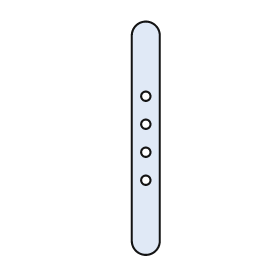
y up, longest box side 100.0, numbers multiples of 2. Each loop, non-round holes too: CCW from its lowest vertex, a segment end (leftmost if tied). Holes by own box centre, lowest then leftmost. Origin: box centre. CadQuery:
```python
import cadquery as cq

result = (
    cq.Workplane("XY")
    .moveTo(-6.0, -44.0)
    .threePointArc((0.0, -50.0), (6.0, -44.0))
    .lineTo(6.0, 44.0)
    .threePointArc((0.0, 50.0), (-6.0, 44.0))
    .close()
    .moveTo(0.0, -18.0)
    .circle(2.0)
    .moveTo(0.0, -6.0)
    .circle(2.0)
    .moveTo(0.0, 6.0)
    .circle(2.0)
    .moveTo(0.0, 18.0)
    .circle(2.0)
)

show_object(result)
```